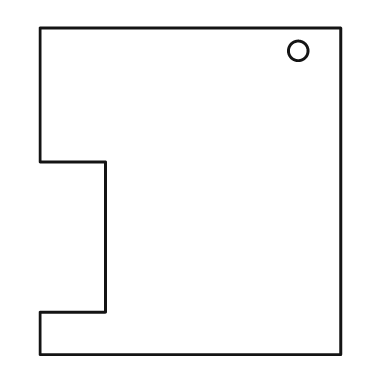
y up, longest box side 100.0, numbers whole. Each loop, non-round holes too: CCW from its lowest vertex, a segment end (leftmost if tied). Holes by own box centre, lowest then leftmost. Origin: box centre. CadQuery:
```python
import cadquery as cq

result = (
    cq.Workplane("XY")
    .moveTo(-46.0, -50.0)
    .lineTo(46.0, -50.0)
    .lineTo(46.0, 50.0)
    .lineTo(-46.0, 50.0)
    .lineTo(-46.0, 9.0)
    .lineTo(-26.0, 9.0)
    .lineTo(-26.0, -37.0)
    .lineTo(-46.0, -37.0)
    .close()
    .moveTo(33.0, 43.0)
    .circle(3.0)
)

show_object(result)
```